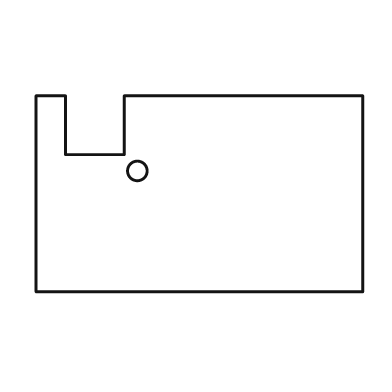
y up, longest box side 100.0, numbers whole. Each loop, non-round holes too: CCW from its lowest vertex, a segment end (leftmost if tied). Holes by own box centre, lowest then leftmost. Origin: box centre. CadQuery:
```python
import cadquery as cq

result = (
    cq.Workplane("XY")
    .moveTo(-50.0, -30.0)
    .lineTo(50.0, -30.0)
    .lineTo(50.0, 30.0)
    .lineTo(-23.0, 30.0)
    .lineTo(-23.0, 12.0)
    .lineTo(-41.0, 12.0)
    .lineTo(-41.0, 30.0)
    .lineTo(-50.0, 30.0)
    .close()
    .moveTo(-19.0, 7.0)
    .circle(3.0)
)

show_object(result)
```